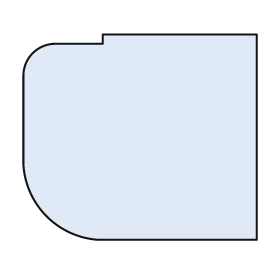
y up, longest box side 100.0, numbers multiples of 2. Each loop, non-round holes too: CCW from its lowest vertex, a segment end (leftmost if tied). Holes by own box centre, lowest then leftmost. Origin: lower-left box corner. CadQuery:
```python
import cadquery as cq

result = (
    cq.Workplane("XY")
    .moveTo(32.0, 0.0)
    .lineTo(100.0, 0.0)
    .lineTo(100.0, 88.0)
    .lineTo(34.0, 88.0)
    .lineTo(34.0, 84.0)
    .lineTo(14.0, 84.0)
    .threePointArc((4.0, 80.0), (0.0, 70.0))
    .lineTo(0.0, 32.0)
    .threePointArc((10.0, 10.0), (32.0, 0.0))
    .close()
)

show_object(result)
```